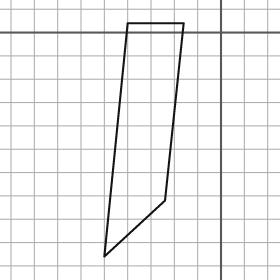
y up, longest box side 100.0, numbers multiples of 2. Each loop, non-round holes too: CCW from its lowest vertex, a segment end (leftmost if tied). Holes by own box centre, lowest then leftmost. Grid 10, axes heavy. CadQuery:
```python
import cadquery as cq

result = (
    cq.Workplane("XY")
    .moveTo(-50.0, -96.0)
    .lineTo(-24.0, -72.0)
    .lineTo(-16.0, 4.0)
    .lineTo(-40.0, 4.0)
    .close()
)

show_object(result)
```